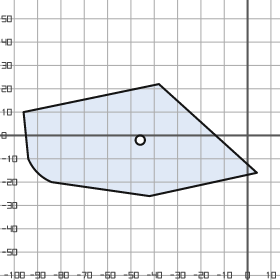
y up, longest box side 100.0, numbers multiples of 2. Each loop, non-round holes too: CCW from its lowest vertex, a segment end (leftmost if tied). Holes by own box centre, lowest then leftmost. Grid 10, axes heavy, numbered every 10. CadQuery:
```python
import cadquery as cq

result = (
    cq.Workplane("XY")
    .moveTo(-42.0, -26.0)
    .lineTo(4.0, -16.0)
    .lineTo(-38.0, 22.0)
    .lineTo(-96.0, 10.0)
    .lineTo(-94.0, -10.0)
    .threePointArc((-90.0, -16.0), (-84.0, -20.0))
    .close()
    .moveTo(-46.0, -2.0)
    .circle(2.0)
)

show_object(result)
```